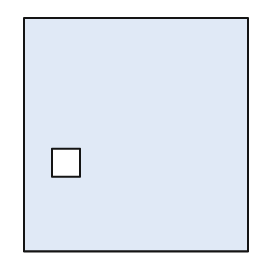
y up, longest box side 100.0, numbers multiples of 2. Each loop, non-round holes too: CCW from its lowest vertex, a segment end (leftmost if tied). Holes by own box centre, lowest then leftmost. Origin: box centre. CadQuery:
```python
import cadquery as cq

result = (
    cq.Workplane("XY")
    .moveTo(-48.0, -50.0)
    .lineTo(48.0, -50.0)
    .lineTo(48.0, 50.0)
    .lineTo(-48.0, 50.0)
    .close()
    .moveTo(-36.0, -18.0)
    .lineTo(-24.0, -18.0)
    .lineTo(-24.0, -6.0)
    .lineTo(-36.0, -6.0)
    .close()
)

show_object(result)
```